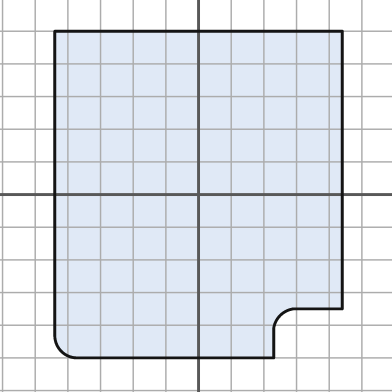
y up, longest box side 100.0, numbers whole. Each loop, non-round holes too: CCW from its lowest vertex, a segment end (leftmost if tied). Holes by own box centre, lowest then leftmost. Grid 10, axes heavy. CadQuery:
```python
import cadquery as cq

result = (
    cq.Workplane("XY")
    .moveTo(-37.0, -50.0)
    .lineTo(23.0, -50.0)
    .lineTo(23.0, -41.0)
    .threePointArc((25.0, -37.0), (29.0, -35.0))
    .lineTo(44.0, -35.0)
    .lineTo(44.0, 50.0)
    .lineTo(-44.0, 50.0)
    .lineTo(-44.0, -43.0)
    .threePointArc((-42.0, -48.0), (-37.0, -50.0))
    .close()
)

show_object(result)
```